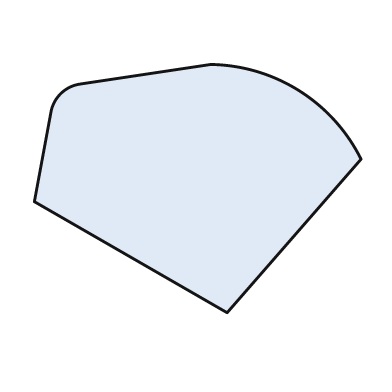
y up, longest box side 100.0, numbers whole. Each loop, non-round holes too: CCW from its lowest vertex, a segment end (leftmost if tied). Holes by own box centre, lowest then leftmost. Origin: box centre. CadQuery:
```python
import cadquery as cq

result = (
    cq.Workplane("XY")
    .moveTo(9.0, -38.0)
    .lineTo(50.0, 9.0)
    .threePointArc((31.0, 30.0), (4.0, 38.0))
    .lineTo(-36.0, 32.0)
    .threePointArc((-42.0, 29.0), (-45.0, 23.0))
    .lineTo(-50.0, -4.0)
    .close()
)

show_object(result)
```